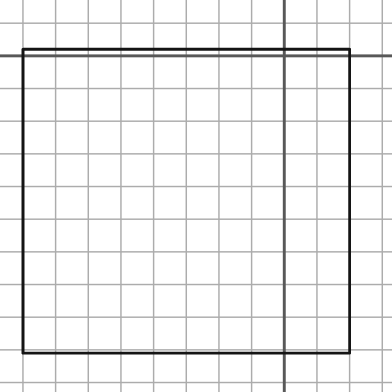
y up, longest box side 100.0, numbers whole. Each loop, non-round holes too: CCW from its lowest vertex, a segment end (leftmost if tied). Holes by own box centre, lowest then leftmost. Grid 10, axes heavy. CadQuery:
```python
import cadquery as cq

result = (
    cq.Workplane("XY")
    .moveTo(-80.0, -91.0)
    .lineTo(20.0, -91.0)
    .lineTo(20.0, 2.0)
    .lineTo(-80.0, 2.0)
    .close()
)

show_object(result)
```